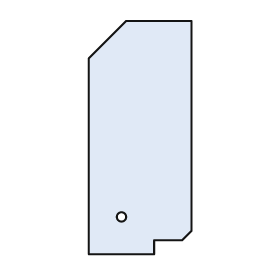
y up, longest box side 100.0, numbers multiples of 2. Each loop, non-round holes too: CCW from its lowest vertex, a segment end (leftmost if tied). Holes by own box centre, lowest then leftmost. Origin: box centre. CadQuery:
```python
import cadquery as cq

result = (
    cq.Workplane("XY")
    .moveTo(-22.0, -50.0)
    .lineTo(6.0, -50.0)
    .lineTo(6.0, -44.0)
    .lineTo(18.0, -44.0)
    .lineTo(22.0, -40.0)
    .lineTo(22.0, 50.0)
    .lineTo(-6.0, 50.0)
    .lineTo(-22.0, 34.0)
    .close()
    .moveTo(-8.0, -34.0)
    .circle(2.0)
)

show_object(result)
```